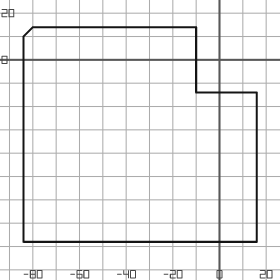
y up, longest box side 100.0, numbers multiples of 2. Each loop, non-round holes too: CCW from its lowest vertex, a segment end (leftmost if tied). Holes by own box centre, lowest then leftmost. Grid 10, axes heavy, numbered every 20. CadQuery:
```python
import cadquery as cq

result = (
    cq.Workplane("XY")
    .moveTo(-84.0, -78.0)
    .lineTo(16.0, -78.0)
    .lineTo(16.0, -14.0)
    .lineTo(-10.0, -14.0)
    .lineTo(-10.0, 14.0)
    .lineTo(-80.0, 14.0)
    .lineTo(-84.0, 10.0)
    .close()
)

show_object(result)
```